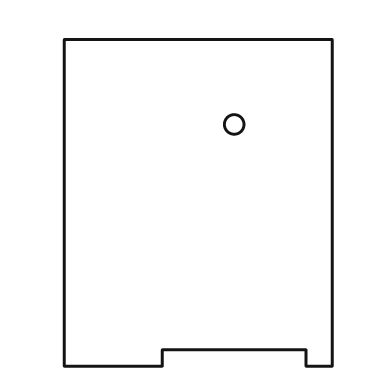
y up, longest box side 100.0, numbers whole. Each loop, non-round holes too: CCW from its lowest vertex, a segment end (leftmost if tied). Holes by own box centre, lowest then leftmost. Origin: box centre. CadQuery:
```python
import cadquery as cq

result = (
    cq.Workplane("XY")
    .moveTo(-41.0, -50.0)
    .lineTo(-11.0, -50.0)
    .lineTo(-11.0, -45.0)
    .lineTo(33.0, -45.0)
    .lineTo(33.0, -50.0)
    .lineTo(41.0, -50.0)
    .lineTo(41.0, 50.0)
    .lineTo(-41.0, 50.0)
    .close()
    .moveTo(11.0, 24.0)
    .circle(3.0)
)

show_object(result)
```